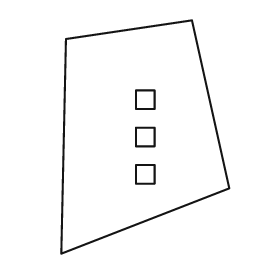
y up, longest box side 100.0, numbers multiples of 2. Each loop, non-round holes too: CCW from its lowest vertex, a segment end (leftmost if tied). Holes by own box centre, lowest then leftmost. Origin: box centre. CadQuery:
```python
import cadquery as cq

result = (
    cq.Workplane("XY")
    .moveTo(-36.0, -50.0)
    .lineTo(36.0, -22.0)
    .lineTo(20.0, 50.0)
    .lineTo(-34.0, 42.0)
    .close()
    .moveTo(-4.0, -20.0)
    .lineTo(4.0, -20.0)
    .lineTo(4.0, -12.0)
    .lineTo(-4.0, -12.0)
    .close()
    .moveTo(-4.0, -4.0)
    .lineTo(4.0, -4.0)
    .lineTo(4.0, 4.0)
    .lineTo(-4.0, 4.0)
    .close()
    .moveTo(-4.0, 12.0)
    .lineTo(4.0, 12.0)
    .lineTo(4.0, 20.0)
    .lineTo(-4.0, 20.0)
    .close()
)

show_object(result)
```